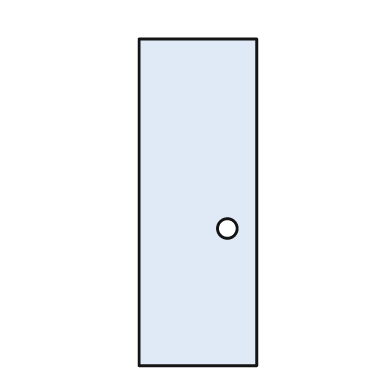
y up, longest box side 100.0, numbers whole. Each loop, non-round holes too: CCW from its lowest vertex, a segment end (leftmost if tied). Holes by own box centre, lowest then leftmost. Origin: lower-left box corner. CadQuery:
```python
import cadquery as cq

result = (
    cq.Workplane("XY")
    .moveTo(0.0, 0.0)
    .lineTo(36.0, 0.0)
    .lineTo(36.0, 100.0)
    .lineTo(0.0, 100.0)
    .close()
    .moveTo(27.0, 42.0)
    .circle(3.0)
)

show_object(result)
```